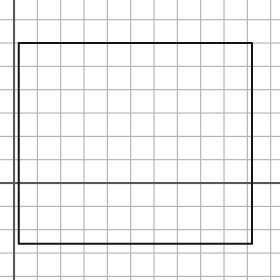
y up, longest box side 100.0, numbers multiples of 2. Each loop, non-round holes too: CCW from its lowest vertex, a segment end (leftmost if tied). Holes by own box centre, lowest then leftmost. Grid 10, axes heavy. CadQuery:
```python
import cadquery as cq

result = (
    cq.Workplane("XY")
    .moveTo(2.0, -26.0)
    .lineTo(102.0, -26.0)
    .lineTo(102.0, 60.0)
    .lineTo(2.0, 60.0)
    .close()
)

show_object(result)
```